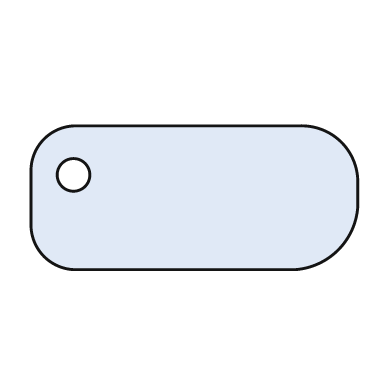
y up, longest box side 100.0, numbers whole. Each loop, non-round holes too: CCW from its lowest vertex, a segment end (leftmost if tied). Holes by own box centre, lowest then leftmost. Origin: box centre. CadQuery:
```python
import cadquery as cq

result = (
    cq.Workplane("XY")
    .moveTo(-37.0, -22.0)
    .lineTo(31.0, -22.0)
    .threePointArc((44.0, -16.0), (50.0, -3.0))
    .lineTo(50.0, 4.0)
    .threePointArc((45.0, 17.0), (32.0, 22.0))
    .lineTo(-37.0, 22.0)
    .threePointArc((-46.0, 18.0), (-50.0, 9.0))
    .lineTo(-50.0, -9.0)
    .threePointArc((-46.0, -18.0), (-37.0, -22.0))
    .close()
    .moveTo(-37.0, 7.0)
    .circle(5.0)
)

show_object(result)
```